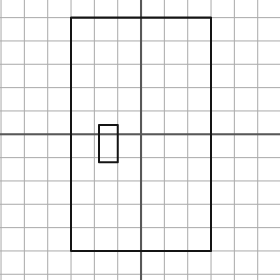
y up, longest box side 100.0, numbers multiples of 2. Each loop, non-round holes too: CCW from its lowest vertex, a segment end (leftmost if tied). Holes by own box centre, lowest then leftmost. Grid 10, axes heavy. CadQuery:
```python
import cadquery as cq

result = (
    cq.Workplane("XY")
    .moveTo(-30.0, -50.0)
    .lineTo(30.0, -50.0)
    .lineTo(30.0, 50.0)
    .lineTo(-30.0, 50.0)
    .close()
    .moveTo(-18.0, -12.0)
    .lineTo(-10.0, -12.0)
    .lineTo(-10.0, 4.0)
    .lineTo(-18.0, 4.0)
    .close()
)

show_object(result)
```